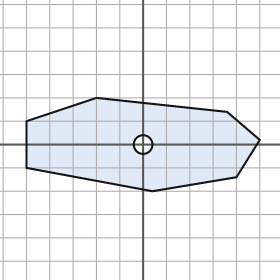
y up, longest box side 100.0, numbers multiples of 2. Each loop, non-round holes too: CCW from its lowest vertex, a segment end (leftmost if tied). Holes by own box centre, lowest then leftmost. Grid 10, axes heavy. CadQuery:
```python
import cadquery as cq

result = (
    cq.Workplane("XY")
    .moveTo(4.0, -20.0)
    .lineTo(40.0, -14.0)
    .lineTo(50.0, 2.0)
    .lineTo(36.0, 14.0)
    .lineTo(-20.0, 20.0)
    .lineTo(-50.0, 10.0)
    .lineTo(-50.0, -10.0)
    .close()
    .moveTo(0.0, 0.0)
    .circle(4.0)
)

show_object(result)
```